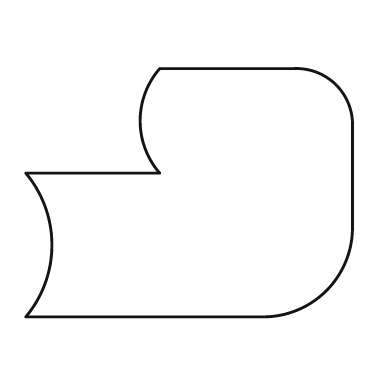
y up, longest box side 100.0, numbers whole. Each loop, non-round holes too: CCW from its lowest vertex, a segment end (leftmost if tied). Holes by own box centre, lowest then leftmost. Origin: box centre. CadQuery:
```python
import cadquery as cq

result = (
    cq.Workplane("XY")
    .moveTo(-50.0, -38.0)
    .lineTo(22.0, -38.0)
    .threePointArc((42.0, -30.0), (50.0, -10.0))
    .lineTo(50.0, 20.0)
    .threePointArc((45.0, 33.0), (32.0, 38.0))
    .lineTo(-9.0, 38.0)
    .threePointArc((-15.0, 22.0), (-9.0, 6.0))
    .lineTo(-50.0, 6.0)
    .threePointArc((-42.0, -16.0), (-50.0, -38.0))
    .close()
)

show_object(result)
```